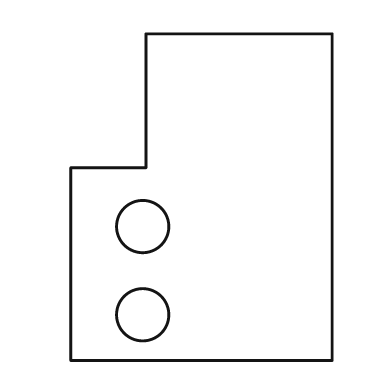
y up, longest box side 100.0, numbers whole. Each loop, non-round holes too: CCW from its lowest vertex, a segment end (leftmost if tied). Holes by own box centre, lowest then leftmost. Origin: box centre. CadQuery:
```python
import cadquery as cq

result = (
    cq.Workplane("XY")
    .moveTo(-40.0, -50.0)
    .lineTo(40.0, -50.0)
    .lineTo(40.0, 50.0)
    .lineTo(-17.0, 50.0)
    .lineTo(-17.0, 9.0)
    .lineTo(-40.0, 9.0)
    .close()
    .moveTo(-18.0, -36.0)
    .circle(8.0)
    .moveTo(-18.0, -9.0)
    .circle(8.0)
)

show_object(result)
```